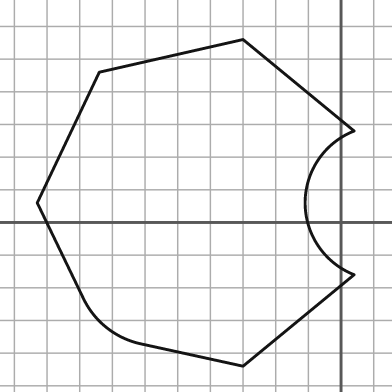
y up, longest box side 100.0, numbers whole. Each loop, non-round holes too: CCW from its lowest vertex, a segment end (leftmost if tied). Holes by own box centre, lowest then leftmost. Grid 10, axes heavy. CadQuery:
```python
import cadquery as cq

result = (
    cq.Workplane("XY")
    .moveTo(-30.0, -44.0)
    .lineTo(4.0, -16.0)
    .threePointArc((-11.0, 6.0), (4.0, 28.0))
    .lineTo(-30.0, 56.0)
    .lineTo(-74.0, 46.0)
    .lineTo(-93.0, 6.0)
    .lineTo(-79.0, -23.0)
    .threePointArc((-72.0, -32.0), (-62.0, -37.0))
    .close()
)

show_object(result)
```